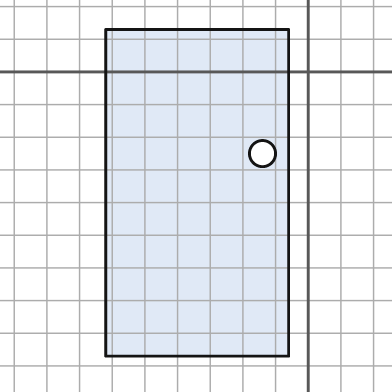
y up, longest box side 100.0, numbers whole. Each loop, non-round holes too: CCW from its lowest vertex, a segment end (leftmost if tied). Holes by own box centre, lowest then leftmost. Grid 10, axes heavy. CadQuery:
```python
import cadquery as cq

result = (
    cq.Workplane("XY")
    .moveTo(-62.0, -87.0)
    .lineTo(-6.0, -87.0)
    .lineTo(-6.0, 13.0)
    .lineTo(-62.0, 13.0)
    .close()
    .moveTo(-14.0, -25.0)
    .circle(4.0)
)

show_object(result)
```